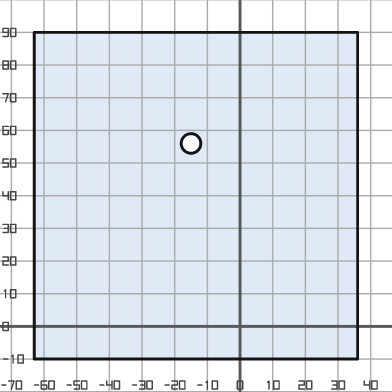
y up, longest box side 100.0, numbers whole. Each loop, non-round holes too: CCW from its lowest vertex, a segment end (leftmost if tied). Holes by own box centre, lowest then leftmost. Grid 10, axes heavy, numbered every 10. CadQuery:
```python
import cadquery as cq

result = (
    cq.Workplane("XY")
    .moveTo(-63.0, -10.0)
    .lineTo(36.0, -10.0)
    .lineTo(36.0, 90.0)
    .lineTo(-63.0, 90.0)
    .close()
    .moveTo(-15.0, 56.0)
    .circle(3.0)
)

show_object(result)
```